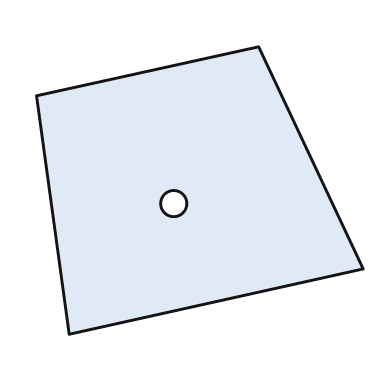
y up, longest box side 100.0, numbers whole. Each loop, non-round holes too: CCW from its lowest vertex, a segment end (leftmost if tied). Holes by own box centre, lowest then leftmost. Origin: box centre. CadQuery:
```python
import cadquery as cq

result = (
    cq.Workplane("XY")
    .moveTo(-40.0, -44.0)
    .lineTo(50.0, -24.0)
    .lineTo(18.0, 44.0)
    .lineTo(-50.0, 29.0)
    .close()
    .moveTo(-8.0, -4.0)
    .circle(4.0)
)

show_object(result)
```